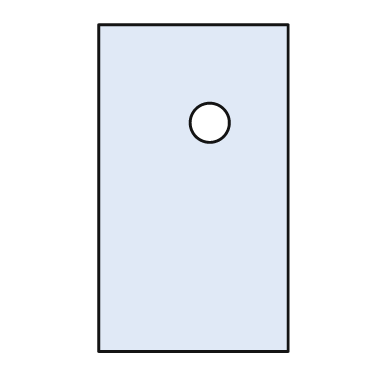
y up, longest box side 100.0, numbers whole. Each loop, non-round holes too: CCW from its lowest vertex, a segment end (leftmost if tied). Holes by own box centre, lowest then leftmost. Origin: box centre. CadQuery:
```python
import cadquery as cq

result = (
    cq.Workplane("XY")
    .moveTo(-29.0, -50.0)
    .lineTo(29.0, -50.0)
    .lineTo(29.0, 50.0)
    .lineTo(-29.0, 50.0)
    .close()
    .moveTo(5.0, 20.0)
    .circle(6.0)
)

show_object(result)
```